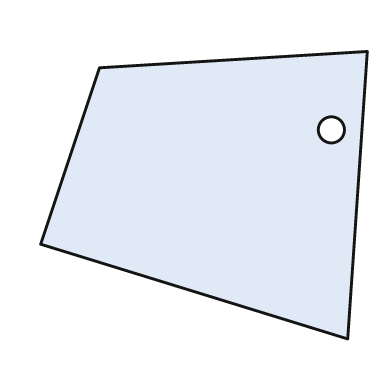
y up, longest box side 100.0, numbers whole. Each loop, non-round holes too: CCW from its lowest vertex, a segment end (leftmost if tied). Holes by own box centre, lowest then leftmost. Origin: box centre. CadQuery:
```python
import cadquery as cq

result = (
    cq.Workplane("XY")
    .moveTo(44.0, -44.0)
    .lineTo(50.0, 44.0)
    .lineTo(-32.0, 39.0)
    .lineTo(-50.0, -15.0)
    .close()
    .moveTo(39.0, 20.0)
    .circle(4.0)
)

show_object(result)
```